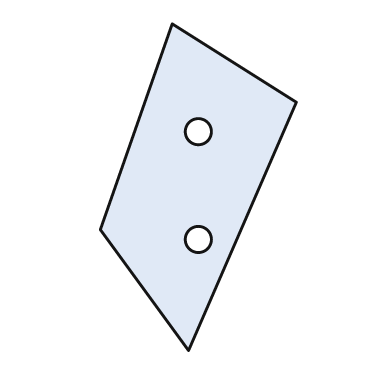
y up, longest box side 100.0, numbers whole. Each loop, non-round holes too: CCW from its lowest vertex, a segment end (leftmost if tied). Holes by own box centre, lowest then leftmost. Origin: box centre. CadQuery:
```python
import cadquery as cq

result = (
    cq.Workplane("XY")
    .moveTo(-3.0, -50.0)
    .lineTo(30.0, 26.0)
    .lineTo(-8.0, 50.0)
    .lineTo(-30.0, -13.0)
    .close()
    .moveTo(0.0, -16.0)
    .circle(4.0)
    .moveTo(0.0, 17.0)
    .circle(4.0)
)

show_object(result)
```